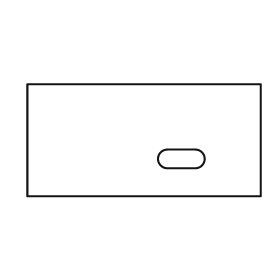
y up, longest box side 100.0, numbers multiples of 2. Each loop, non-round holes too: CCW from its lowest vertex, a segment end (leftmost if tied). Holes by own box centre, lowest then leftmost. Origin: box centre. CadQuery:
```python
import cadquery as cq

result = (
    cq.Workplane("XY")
    .moveTo(-50.0, -24.0)
    .lineTo(50.0, -24.0)
    .lineTo(50.0, 24.0)
    .lineTo(-50.0, 24.0)
    .close()
    .moveTo(10.0, -12.0)
    .lineTo(22.0, -12.0)
    .threePointArc((26.0, -8.0), (22.0, -4.0))
    .lineTo(10.0, -4.0)
    .threePointArc((6.0, -8.0), (10.0, -12.0))
    .close()
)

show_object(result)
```